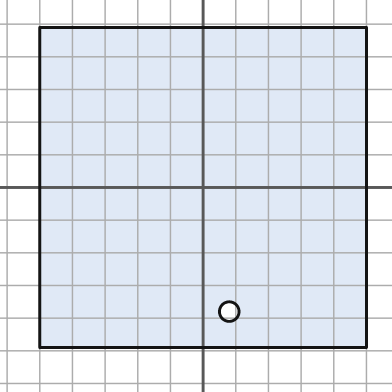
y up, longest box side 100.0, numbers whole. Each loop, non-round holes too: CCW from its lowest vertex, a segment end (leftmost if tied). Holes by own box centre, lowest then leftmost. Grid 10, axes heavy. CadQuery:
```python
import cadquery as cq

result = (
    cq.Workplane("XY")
    .moveTo(-50.0, -49.0)
    .lineTo(50.0, -49.0)
    .lineTo(50.0, 49.0)
    .lineTo(-50.0, 49.0)
    .close()
    .moveTo(8.0, -38.0)
    .circle(3.0)
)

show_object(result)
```